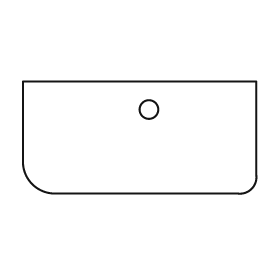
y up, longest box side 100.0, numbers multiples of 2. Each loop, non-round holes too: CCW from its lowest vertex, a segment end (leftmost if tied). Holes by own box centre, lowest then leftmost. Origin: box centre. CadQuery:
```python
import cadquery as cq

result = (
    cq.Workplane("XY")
    .moveTo(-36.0, -24.0)
    .lineTo(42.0, -24.0)
    .threePointArc((48.0, -22.0), (50.0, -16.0))
    .lineTo(50.0, 24.0)
    .lineTo(-50.0, 24.0)
    .lineTo(-50.0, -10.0)
    .threePointArc((-46.0, -20.0), (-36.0, -24.0))
    .close()
    .moveTo(4.0, 12.0)
    .circle(4.0)
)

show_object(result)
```